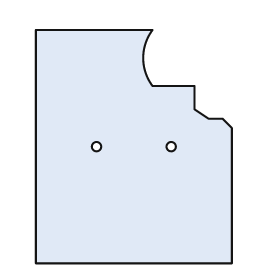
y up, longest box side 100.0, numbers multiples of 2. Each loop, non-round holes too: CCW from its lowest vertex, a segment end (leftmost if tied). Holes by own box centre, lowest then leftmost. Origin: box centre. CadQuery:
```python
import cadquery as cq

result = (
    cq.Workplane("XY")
    .moveTo(-42.0, -50.0)
    .lineTo(42.0, -50.0)
    .lineTo(42.0, 8.0)
    .lineTo(38.0, 12.0)
    .lineTo(32.0, 12.0)
    .lineTo(26.0, 16.0)
    .lineTo(26.0, 26.0)
    .lineTo(8.0, 26.0)
    .threePointArc((4.0, 38.0), (8.0, 50.0))
    .lineTo(-42.0, 50.0)
    .close()
    .moveTo(-16.0, 0.0)
    .circle(2.0)
    .moveTo(16.0, 0.0)
    .circle(2.0)
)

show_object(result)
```